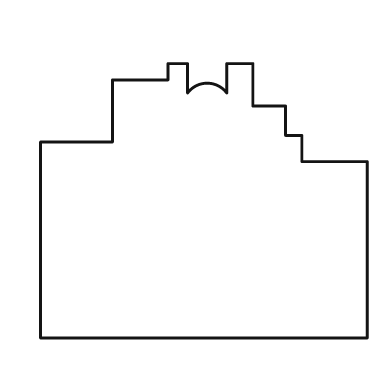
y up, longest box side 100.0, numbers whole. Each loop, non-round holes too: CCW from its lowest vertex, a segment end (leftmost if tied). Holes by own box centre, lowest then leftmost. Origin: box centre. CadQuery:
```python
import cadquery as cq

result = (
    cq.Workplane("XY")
    .moveTo(-50.0, -42.0)
    .lineTo(50.0, -42.0)
    .lineTo(50.0, 12.0)
    .lineTo(30.0, 12.0)
    .lineTo(30.0, 20.0)
    .lineTo(25.0, 20.0)
    .lineTo(25.0, 29.0)
    .lineTo(15.0, 29.0)
    .lineTo(15.0, 42.0)
    .lineTo(7.0, 42.0)
    .lineTo(7.0, 33.0)
    .threePointArc((1.0, 36.0), (-5.0, 33.0))
    .lineTo(-5.0, 42.0)
    .lineTo(-11.0, 42.0)
    .lineTo(-11.0, 37.0)
    .lineTo(-28.0, 37.0)
    .lineTo(-28.0, 18.0)
    .lineTo(-50.0, 18.0)
    .close()
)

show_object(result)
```